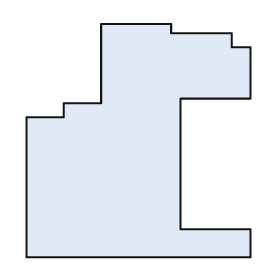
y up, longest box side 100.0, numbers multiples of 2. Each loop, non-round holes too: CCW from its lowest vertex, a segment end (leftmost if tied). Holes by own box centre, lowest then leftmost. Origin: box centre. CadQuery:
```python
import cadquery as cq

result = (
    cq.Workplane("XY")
    .moveTo(-48.0, -50.0)
    .lineTo(48.0, -50.0)
    .lineTo(48.0, -38.0)
    .lineTo(18.0, -38.0)
    .lineTo(18.0, 18.0)
    .lineTo(48.0, 18.0)
    .lineTo(48.0, 40.0)
    .lineTo(40.0, 40.0)
    .lineTo(40.0, 46.0)
    .lineTo(14.0, 46.0)
    .lineTo(14.0, 50.0)
    .lineTo(-16.0, 50.0)
    .lineTo(-16.0, 16.0)
    .lineTo(-32.0, 16.0)
    .lineTo(-32.0, 10.0)
    .lineTo(-48.0, 10.0)
    .close()
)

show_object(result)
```